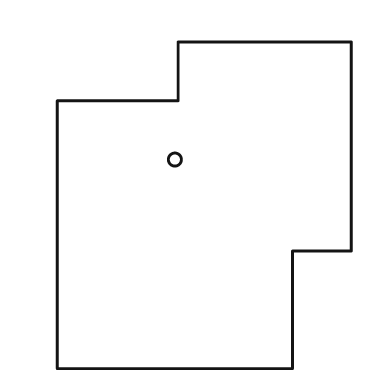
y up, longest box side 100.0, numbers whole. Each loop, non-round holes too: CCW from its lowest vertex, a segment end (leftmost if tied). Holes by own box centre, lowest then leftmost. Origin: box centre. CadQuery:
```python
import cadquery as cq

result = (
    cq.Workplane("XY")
    .moveTo(-45.0, -50.0)
    .lineTo(27.0, -50.0)
    .lineTo(27.0, -14.0)
    .lineTo(45.0, -14.0)
    .lineTo(45.0, 50.0)
    .lineTo(-8.0, 50.0)
    .lineTo(-8.0, 32.0)
    .lineTo(-45.0, 32.0)
    .close()
    .moveTo(-9.0, 14.0)
    .circle(2.0)
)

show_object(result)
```